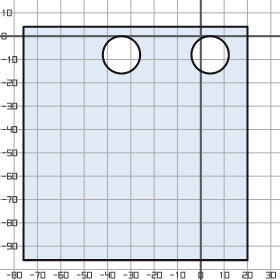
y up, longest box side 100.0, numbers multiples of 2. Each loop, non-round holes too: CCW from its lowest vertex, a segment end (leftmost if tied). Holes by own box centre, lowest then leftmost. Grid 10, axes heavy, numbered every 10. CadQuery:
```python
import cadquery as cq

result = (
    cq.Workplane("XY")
    .moveTo(-76.0, -96.0)
    .lineTo(20.0, -96.0)
    .lineTo(20.0, 4.0)
    .lineTo(-76.0, 4.0)
    .close()
    .moveTo(-34.0, -8.0)
    .circle(8.0)
    .moveTo(4.0, -8.0)
    .circle(8.0)
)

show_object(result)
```